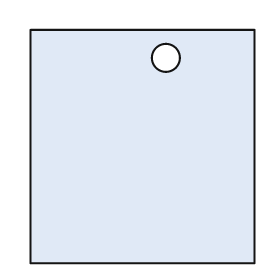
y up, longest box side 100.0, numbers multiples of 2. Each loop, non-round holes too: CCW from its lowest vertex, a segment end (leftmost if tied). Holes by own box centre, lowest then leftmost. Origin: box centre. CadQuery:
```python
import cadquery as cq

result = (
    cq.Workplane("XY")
    .moveTo(-48.0, -50.0)
    .lineTo(48.0, -50.0)
    .lineTo(48.0, 50.0)
    .lineTo(-48.0, 50.0)
    .close()
    .moveTo(10.0, 38.0)
    .circle(6.0)
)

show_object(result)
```